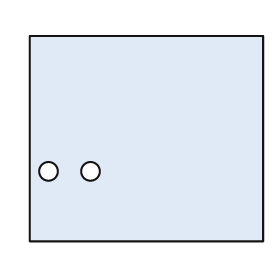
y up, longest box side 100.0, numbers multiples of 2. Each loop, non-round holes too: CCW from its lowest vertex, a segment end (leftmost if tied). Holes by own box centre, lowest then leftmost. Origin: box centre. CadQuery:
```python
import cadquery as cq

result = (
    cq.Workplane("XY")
    .moveTo(-50.0, -44.0)
    .lineTo(50.0, -44.0)
    .lineTo(50.0, 44.0)
    .lineTo(-50.0, 44.0)
    .close()
    .moveTo(-42.0, -14.0)
    .circle(4.0)
    .moveTo(-24.0, -14.0)
    .circle(4.0)
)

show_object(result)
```